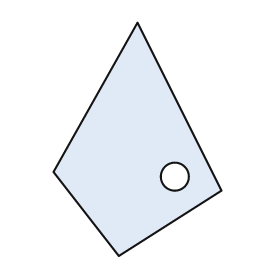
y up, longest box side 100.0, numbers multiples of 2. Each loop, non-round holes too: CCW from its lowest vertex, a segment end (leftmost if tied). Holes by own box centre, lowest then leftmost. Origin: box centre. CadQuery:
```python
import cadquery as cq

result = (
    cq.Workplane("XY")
    .moveTo(-8.0, -50.0)
    .lineTo(36.0, -22.0)
    .lineTo(0.0, 50.0)
    .lineTo(-36.0, -14.0)
    .close()
    .moveTo(16.0, -16.0)
    .circle(6.0)
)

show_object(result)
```